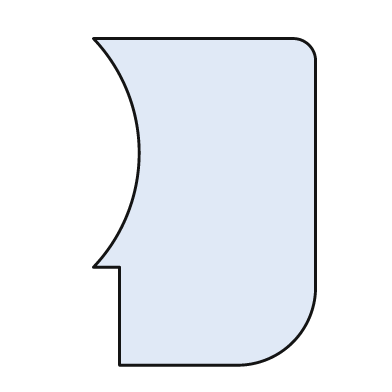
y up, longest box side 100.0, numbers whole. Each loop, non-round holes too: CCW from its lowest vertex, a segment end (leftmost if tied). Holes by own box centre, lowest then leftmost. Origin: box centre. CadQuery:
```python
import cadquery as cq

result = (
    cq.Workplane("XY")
    .moveTo(-26.0, -50.0)
    .lineTo(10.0, -50.0)
    .threePointArc((27.0, -43.0), (34.0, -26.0))
    .lineTo(34.0, 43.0)
    .threePointArc((32.0, 48.0), (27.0, 50.0))
    .lineTo(-34.0, 50.0)
    .threePointArc((-20.0, 15.0), (-34.0, -20.0))
    .lineTo(-26.0, -20.0)
    .close()
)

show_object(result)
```